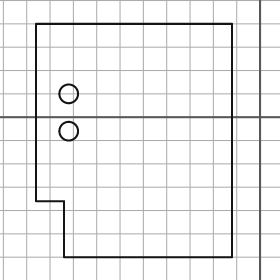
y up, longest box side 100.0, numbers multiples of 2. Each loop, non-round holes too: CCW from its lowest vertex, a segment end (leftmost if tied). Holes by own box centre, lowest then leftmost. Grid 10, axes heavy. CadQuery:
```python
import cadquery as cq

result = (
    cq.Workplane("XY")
    .moveTo(-84.0, -60.0)
    .lineTo(-12.0, -60.0)
    .lineTo(-12.0, 40.0)
    .lineTo(-96.0, 40.0)
    .lineTo(-96.0, -36.0)
    .lineTo(-84.0, -36.0)
    .close()
    .moveTo(-82.0, -6.0)
    .circle(4.0)
    .moveTo(-82.0, 10.0)
    .circle(4.0)
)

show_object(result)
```